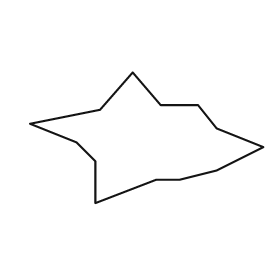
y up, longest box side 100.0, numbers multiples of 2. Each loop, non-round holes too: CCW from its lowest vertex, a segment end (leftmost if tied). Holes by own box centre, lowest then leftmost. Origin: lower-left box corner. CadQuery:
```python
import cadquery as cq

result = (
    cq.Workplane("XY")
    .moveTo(28.0, 0.0)
    .lineTo(54.0, 10.0)
    .lineTo(64.0, 10.0)
    .lineTo(80.0, 14.0)
    .lineTo(100.0, 24.0)
    .lineTo(80.0, 32.0)
    .lineTo(72.0, 42.0)
    .lineTo(56.0, 42.0)
    .lineTo(44.0, 56.0)
    .lineTo(30.0, 40.0)
    .lineTo(0.0, 34.0)
    .lineTo(20.0, 26.0)
    .lineTo(28.0, 18.0)
    .close()
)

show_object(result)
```